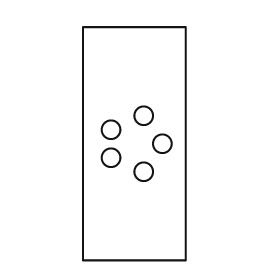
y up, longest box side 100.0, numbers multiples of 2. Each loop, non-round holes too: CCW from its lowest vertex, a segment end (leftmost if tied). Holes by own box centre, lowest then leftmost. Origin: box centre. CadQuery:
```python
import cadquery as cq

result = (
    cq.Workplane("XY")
    .moveTo(-22.0, -50.0)
    .lineTo(22.0, -50.0)
    .lineTo(22.0, 50.0)
    .lineTo(-22.0, 50.0)
    .close()
    .moveTo(4.0, -12.0)
    .circle(4.0)
    .moveTo(-10.0, -6.0)
    .circle(4.0)
    .moveTo(12.0, 0.0)
    .circle(4.0)
    .moveTo(-10.0, 6.0)
    .circle(4.0)
    .moveTo(4.0, 12.0)
    .circle(4.0)
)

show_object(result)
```